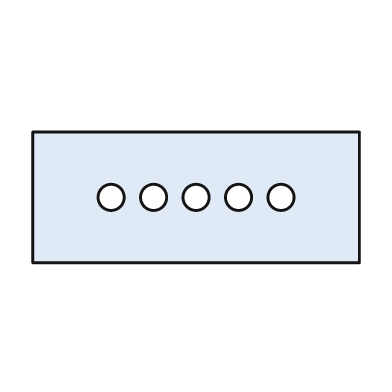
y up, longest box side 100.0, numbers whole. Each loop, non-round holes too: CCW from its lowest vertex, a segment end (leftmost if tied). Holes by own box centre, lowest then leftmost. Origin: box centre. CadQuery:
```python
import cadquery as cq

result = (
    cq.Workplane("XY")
    .moveTo(-50.0, -20.0)
    .lineTo(50.0, -20.0)
    .lineTo(50.0, 20.0)
    .lineTo(-50.0, 20.0)
    .close()
    .moveTo(-26.0, 0.0)
    .circle(4.0)
    .moveTo(-13.0, 0.0)
    .circle(4.0)
    .moveTo(0.0, 0.0)
    .circle(4.0)
    .moveTo(13.0, 0.0)
    .circle(4.0)
    .moveTo(26.0, 0.0)
    .circle(4.0)
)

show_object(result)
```